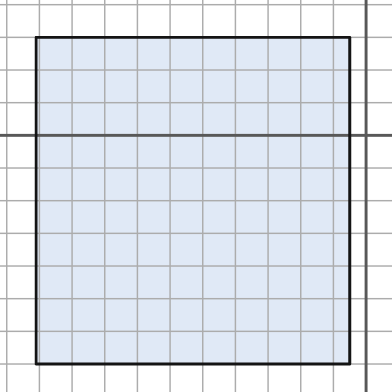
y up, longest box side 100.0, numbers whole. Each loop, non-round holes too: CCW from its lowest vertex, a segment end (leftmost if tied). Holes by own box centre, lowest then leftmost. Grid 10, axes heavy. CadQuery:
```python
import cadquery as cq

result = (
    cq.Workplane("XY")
    .moveTo(-101.0, -70.0)
    .lineTo(-5.0, -70.0)
    .lineTo(-5.0, 30.0)
    .lineTo(-101.0, 30.0)
    .close()
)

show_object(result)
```